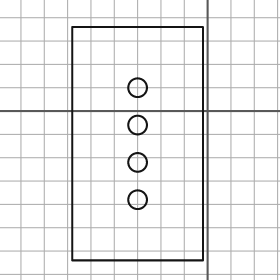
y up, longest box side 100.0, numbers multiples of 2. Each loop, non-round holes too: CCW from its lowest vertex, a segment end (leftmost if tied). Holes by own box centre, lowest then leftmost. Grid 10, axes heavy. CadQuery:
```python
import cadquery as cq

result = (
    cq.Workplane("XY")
    .moveTo(-58.0, -64.0)
    .lineTo(-2.0, -64.0)
    .lineTo(-2.0, 36.0)
    .lineTo(-58.0, 36.0)
    .close()
    .moveTo(-30.0, -38.0)
    .circle(4.0)
    .moveTo(-30.0, -22.0)
    .circle(4.0)
    .moveTo(-30.0, -6.0)
    .circle(4.0)
    .moveTo(-30.0, 10.0)
    .circle(4.0)
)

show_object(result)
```